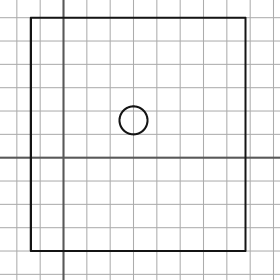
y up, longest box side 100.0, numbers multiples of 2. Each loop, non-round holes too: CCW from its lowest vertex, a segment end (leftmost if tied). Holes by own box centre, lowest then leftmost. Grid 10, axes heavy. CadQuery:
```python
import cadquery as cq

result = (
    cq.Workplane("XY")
    .moveTo(-14.0, -40.0)
    .lineTo(78.0, -40.0)
    .lineTo(78.0, 60.0)
    .lineTo(-14.0, 60.0)
    .close()
    .moveTo(30.0, 16.0)
    .circle(6.0)
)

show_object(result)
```